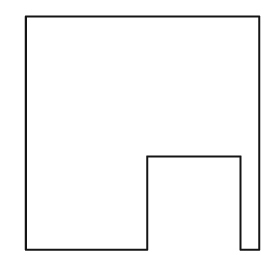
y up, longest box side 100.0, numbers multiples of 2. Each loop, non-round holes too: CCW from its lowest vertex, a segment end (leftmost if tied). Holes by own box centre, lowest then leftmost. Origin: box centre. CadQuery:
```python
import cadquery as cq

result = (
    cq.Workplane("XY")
    .moveTo(-50.0, -50.0)
    .lineTo(2.0, -50.0)
    .lineTo(2.0, -10.0)
    .lineTo(42.0, -10.0)
    .lineTo(42.0, -50.0)
    .lineTo(50.0, -50.0)
    .lineTo(50.0, 50.0)
    .lineTo(-50.0, 50.0)
    .close()
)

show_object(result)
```